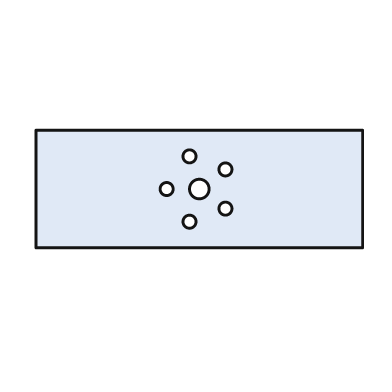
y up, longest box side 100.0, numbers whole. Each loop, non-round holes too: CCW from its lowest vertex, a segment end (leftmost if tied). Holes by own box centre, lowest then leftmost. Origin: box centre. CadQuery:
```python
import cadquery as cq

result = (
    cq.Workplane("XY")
    .moveTo(-50.0, -18.0)
    .lineTo(50.0, -18.0)
    .lineTo(50.0, 18.0)
    .lineTo(-50.0, 18.0)
    .close()
    .moveTo(-3.0, -10.0)
    .circle(2.0)
    .moveTo(8.0, -6.0)
    .circle(2.0)
    .moveTo(-10.0, 0.0)
    .circle(2.0)
    .moveTo(0.0, 0.0)
    .circle(3.0)
    .moveTo(8.0, 6.0)
    .circle(2.0)
    .moveTo(-3.0, 10.0)
    .circle(2.0)
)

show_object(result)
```